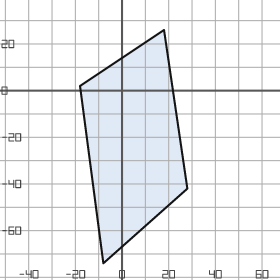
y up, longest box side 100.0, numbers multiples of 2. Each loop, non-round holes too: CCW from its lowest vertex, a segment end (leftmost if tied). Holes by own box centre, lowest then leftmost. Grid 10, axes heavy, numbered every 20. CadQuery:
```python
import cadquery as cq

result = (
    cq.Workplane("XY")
    .moveTo(-8.0, -74.0)
    .lineTo(28.0, -42.0)
    .lineTo(18.0, 26.0)
    .lineTo(-18.0, 2.0)
    .close()
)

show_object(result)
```